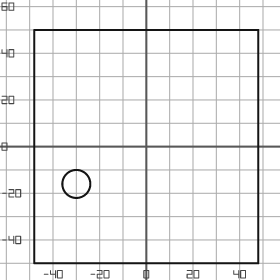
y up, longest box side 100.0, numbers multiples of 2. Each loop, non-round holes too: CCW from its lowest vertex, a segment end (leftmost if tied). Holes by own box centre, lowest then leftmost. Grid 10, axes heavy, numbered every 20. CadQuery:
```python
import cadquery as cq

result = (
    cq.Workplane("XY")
    .moveTo(-48.0, -50.0)
    .lineTo(48.0, -50.0)
    .lineTo(48.0, 50.0)
    .lineTo(-48.0, 50.0)
    .close()
    .moveTo(-30.0, -16.0)
    .circle(6.0)
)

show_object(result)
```